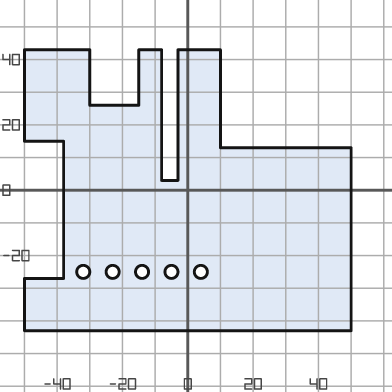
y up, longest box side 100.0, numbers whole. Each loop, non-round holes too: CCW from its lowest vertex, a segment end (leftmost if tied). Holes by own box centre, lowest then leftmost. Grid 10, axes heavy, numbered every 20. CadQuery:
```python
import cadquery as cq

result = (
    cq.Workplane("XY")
    .moveTo(-50.0, -43.0)
    .lineTo(50.0, -43.0)
    .lineTo(50.0, 13.0)
    .lineTo(10.0, 13.0)
    .lineTo(10.0, 43.0)
    .lineTo(-3.0, 43.0)
    .lineTo(-3.0, 3.0)
    .lineTo(-8.0, 3.0)
    .lineTo(-8.0, 43.0)
    .lineTo(-15.0, 43.0)
    .lineTo(-15.0, 26.0)
    .lineTo(-30.0, 26.0)
    .lineTo(-30.0, 43.0)
    .lineTo(-50.0, 43.0)
    .lineTo(-50.0, 15.0)
    .lineTo(-38.0, 15.0)
    .lineTo(-38.0, -27.0)
    .lineTo(-50.0, -27.0)
    .close()
    .moveTo(-32.0, -25.0)
    .circle(2.0)
    .moveTo(-23.0, -25.0)
    .circle(2.0)
    .moveTo(-14.0, -25.0)
    .circle(2.0)
    .moveTo(-5.0, -25.0)
    .circle(2.0)
    .moveTo(4.0, -25.0)
    .circle(2.0)
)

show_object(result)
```